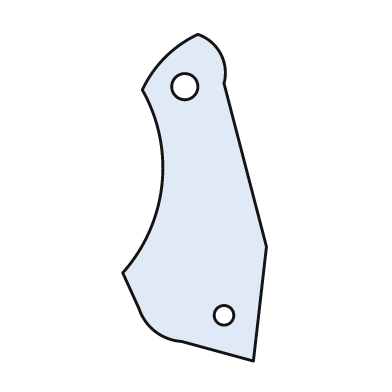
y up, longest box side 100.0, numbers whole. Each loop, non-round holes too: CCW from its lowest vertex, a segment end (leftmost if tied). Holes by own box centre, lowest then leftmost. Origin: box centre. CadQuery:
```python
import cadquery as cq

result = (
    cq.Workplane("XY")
    .moveTo(18.0, -50.0)
    .lineTo(22.0, -15.0)
    .lineTo(9.0, 35.0)
    .threePointArc((8.0, 44.0), (1.0, 50.0))
    .threePointArc((-9.0, 43.0), (-16.0, 33.0))
    .threePointArc((-10.0, 4.0), (-22.0, -23.0))
    .lineTo(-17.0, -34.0)
    .threePointArc((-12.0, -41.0), (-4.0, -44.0))
    .close()
    .moveTo(9.0, -36.0)
    .circle(3.0)
    .moveTo(-3.0, 34.0)
    .circle(4.0)
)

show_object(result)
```